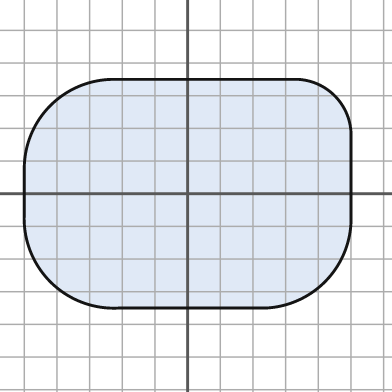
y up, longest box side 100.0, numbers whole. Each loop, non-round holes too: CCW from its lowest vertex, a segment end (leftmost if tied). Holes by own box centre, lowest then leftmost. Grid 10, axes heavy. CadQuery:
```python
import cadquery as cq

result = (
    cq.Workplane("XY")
    .moveTo(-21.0, -35.0)
    .lineTo(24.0, -35.0)
    .threePointArc((42.0, -27.0), (50.0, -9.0))
    .lineTo(50.0, 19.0)
    .threePointArc((45.0, 30.0), (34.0, 35.0))
    .lineTo(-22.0, 35.0)
    .threePointArc((-42.0, 27.0), (-50.0, 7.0))
    .lineTo(-50.0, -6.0)
    .threePointArc((-42.0, -27.0), (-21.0, -35.0))
    .close()
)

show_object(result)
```